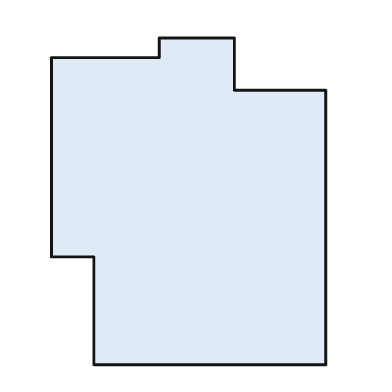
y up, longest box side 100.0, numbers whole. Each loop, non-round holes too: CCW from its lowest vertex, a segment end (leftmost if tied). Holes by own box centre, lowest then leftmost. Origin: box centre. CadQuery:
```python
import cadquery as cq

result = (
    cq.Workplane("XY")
    .moveTo(-29.0, -50.0)
    .lineTo(42.0, -50.0)
    .lineTo(42.0, 34.0)
    .lineTo(14.0, 34.0)
    .lineTo(14.0, 50.0)
    .lineTo(-9.0, 50.0)
    .lineTo(-9.0, 44.0)
    .lineTo(-42.0, 44.0)
    .lineTo(-42.0, -17.0)
    .lineTo(-29.0, -17.0)
    .close()
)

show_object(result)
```